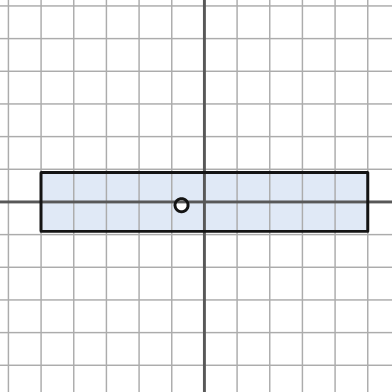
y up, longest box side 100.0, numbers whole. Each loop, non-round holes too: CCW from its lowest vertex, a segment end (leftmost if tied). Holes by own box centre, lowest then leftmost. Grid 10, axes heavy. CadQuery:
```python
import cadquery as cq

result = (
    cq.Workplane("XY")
    .moveTo(-50.0, -9.0)
    .lineTo(50.0, -9.0)
    .lineTo(50.0, 9.0)
    .lineTo(-50.0, 9.0)
    .close()
    .moveTo(-7.0, -1.0)
    .circle(2.0)
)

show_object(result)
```